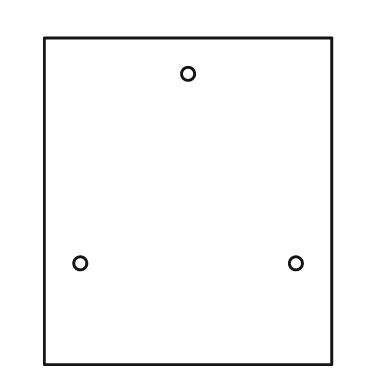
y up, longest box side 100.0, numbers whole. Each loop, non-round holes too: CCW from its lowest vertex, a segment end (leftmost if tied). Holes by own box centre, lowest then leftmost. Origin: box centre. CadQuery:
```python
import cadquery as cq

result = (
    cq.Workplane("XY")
    .moveTo(-44.0, -50.0)
    .lineTo(44.0, -50.0)
    .lineTo(44.0, 50.0)
    .lineTo(-44.0, 50.0)
    .close()
    .moveTo(-33.0, -19.0)
    .circle(2.0)
    .moveTo(33.0, -19.0)
    .circle(2.0)
    .moveTo(0.0, 39.0)
    .circle(2.0)
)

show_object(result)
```